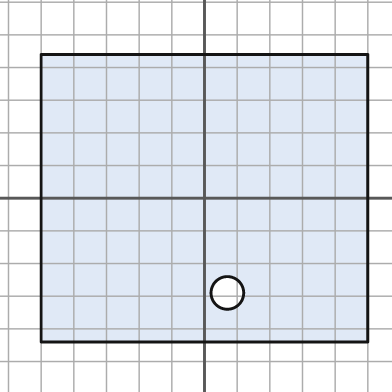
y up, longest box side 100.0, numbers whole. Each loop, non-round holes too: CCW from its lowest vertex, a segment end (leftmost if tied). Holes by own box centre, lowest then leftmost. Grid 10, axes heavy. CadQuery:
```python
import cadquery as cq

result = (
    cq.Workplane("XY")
    .moveTo(-50.0, -44.0)
    .lineTo(50.0, -44.0)
    .lineTo(50.0, 44.0)
    .lineTo(-50.0, 44.0)
    .close()
    .moveTo(7.0, -29.0)
    .circle(5.0)
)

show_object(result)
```